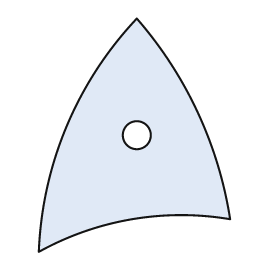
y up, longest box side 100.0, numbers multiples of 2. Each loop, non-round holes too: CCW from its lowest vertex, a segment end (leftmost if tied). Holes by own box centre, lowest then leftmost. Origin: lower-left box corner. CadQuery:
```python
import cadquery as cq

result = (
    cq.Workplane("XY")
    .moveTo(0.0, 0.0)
    .threePointArc((40.0, 14.0), (82.0, 14.0))
    .threePointArc((68.0, 60.0), (42.0, 100.0))
    .threePointArc((12.0, 54.0), (0.0, 0.0))
    .close()
    .moveTo(42.0, 50.0)
    .circle(6.0)
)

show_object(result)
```